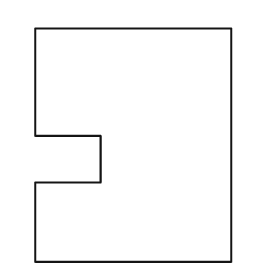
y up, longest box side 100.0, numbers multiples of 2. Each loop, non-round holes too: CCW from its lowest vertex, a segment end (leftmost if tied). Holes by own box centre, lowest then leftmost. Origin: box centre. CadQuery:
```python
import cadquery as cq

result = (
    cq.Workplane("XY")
    .moveTo(-42.0, -50.0)
    .lineTo(42.0, -50.0)
    .lineTo(42.0, 50.0)
    .lineTo(-42.0, 50.0)
    .lineTo(-42.0, 4.0)
    .lineTo(-14.0, 4.0)
    .lineTo(-14.0, -16.0)
    .lineTo(-42.0, -16.0)
    .close()
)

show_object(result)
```